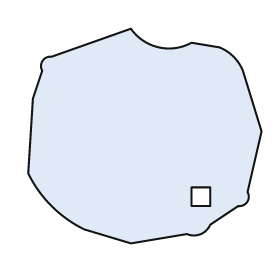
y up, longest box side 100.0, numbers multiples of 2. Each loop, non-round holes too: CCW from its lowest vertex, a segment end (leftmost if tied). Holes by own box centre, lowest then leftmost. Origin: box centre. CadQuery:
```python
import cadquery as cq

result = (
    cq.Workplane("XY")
    .moveTo(-6.0, -46.0)
    .lineTo(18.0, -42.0)
    .threePointArc((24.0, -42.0), (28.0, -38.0))
    .lineTo(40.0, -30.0)
    .threePointArc((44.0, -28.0), (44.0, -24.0))
    .lineTo(50.0, 2.0)
    .lineTo(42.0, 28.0)
    .threePointArc((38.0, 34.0), (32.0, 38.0))
    .lineTo(20.0, 40.0)
    .threePointArc((6.0, 38.0), (-6.0, 46.0))
    .lineTo(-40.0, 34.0)
    .threePointArc((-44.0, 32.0), (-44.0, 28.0))
    .lineTo(-48.0, 16.0)
    .lineTo(-50.0, -16.0)
    .threePointArc((-40.0, -30.0), (-26.0, -40.0))
    .close()
    .moveTo(20.0, -30.0)
    .lineTo(28.0, -30.0)
    .lineTo(28.0, -22.0)
    .lineTo(20.0, -22.0)
    .close()
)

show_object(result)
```